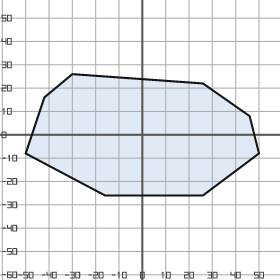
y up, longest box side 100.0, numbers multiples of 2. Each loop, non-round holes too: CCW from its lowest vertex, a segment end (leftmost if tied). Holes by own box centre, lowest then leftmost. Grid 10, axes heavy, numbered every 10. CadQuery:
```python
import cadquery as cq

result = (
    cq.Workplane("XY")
    .moveTo(-16.0, -26.0)
    .lineTo(26.0, -26.0)
    .lineTo(50.0, -8.0)
    .lineTo(46.0, 8.0)
    .lineTo(26.0, 22.0)
    .lineTo(-30.0, 26.0)
    .lineTo(-42.0, 16.0)
    .lineTo(-50.0, -8.0)
    .close()
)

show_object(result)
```